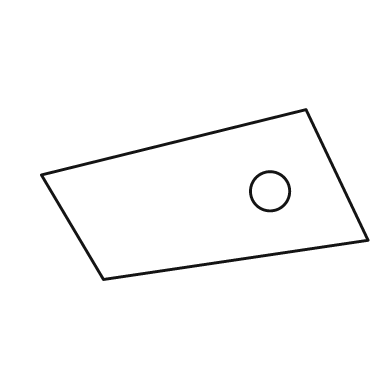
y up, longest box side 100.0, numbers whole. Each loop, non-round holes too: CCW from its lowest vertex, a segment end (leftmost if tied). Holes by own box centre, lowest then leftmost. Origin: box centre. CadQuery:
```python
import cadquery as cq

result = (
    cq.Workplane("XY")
    .moveTo(-31.0, -26.0)
    .lineTo(50.0, -14.0)
    .lineTo(31.0, 26.0)
    .lineTo(-50.0, 6.0)
    .close()
    .moveTo(20.0, 1.0)
    .circle(6.0)
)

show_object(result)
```